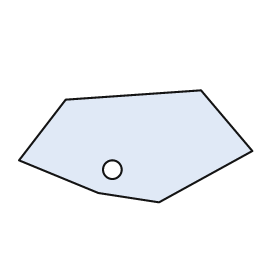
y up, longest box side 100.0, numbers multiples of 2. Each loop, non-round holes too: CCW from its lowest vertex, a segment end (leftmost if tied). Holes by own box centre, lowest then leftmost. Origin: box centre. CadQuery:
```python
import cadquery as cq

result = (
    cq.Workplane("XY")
    .moveTo(10.0, -24.0)
    .lineTo(50.0, -2.0)
    .lineTo(28.0, 24.0)
    .lineTo(-30.0, 20.0)
    .lineTo(-50.0, -6.0)
    .lineTo(-16.0, -20.0)
    .close()
    .moveTo(-10.0, -10.0)
    .circle(4.0)
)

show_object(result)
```